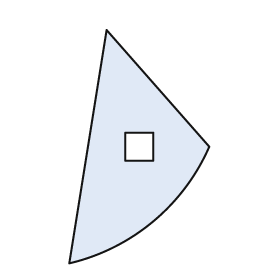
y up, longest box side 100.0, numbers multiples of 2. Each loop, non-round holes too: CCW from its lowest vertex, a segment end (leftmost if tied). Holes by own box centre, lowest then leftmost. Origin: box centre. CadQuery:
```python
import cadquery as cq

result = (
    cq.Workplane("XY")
    .moveTo(-30.0, -50.0)
    .threePointArc((6.0, -32.0), (30.0, 0.0))
    .lineTo(-14.0, 50.0)
    .close()
    .moveTo(-6.0, -6.0)
    .lineTo(6.0, -6.0)
    .lineTo(6.0, 6.0)
    .lineTo(-6.0, 6.0)
    .close()
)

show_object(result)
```